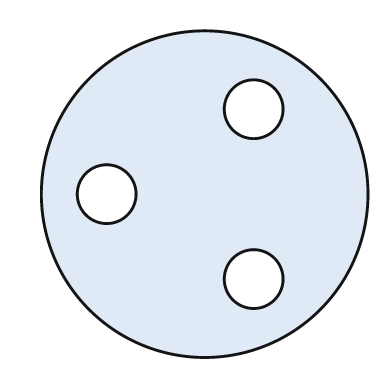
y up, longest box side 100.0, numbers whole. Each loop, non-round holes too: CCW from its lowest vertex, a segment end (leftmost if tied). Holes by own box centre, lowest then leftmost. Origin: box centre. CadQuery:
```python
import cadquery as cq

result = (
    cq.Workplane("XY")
    .moveTo(0.0, 0.0)
    .circle(50.0)
    .moveTo(15.0, -26.0)
    .circle(9.0)
    .moveTo(-30.0, 0.0)
    .circle(9.0)
    .moveTo(15.0, 26.0)
    .circle(9.0)
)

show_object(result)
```